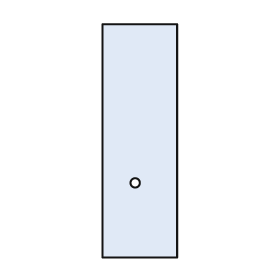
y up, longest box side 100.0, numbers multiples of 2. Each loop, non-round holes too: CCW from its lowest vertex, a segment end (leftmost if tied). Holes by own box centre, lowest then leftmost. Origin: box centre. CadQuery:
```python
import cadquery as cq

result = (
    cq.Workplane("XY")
    .moveTo(-16.0, -50.0)
    .lineTo(16.0, -50.0)
    .lineTo(16.0, 50.0)
    .lineTo(-16.0, 50.0)
    .close()
    .moveTo(-2.0, -18.0)
    .circle(2.0)
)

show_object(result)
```